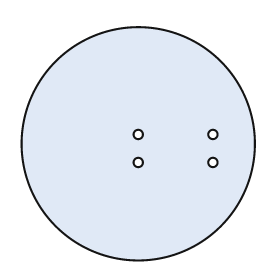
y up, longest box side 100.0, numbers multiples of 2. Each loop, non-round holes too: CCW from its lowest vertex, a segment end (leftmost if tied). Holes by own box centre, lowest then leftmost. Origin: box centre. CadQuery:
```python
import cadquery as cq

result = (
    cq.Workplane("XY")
    .moveTo(0.0, 0.0)
    .circle(50.0)
    .moveTo(0.0, -8.0)
    .circle(2.0)
    .moveTo(32.0, -8.0)
    .circle(2.0)
    .moveTo(0.0, 4.0)
    .circle(2.0)
    .moveTo(32.0, 4.0)
    .circle(2.0)
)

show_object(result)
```